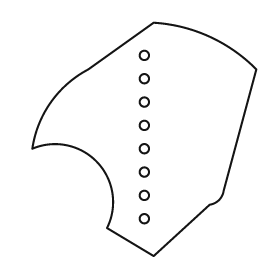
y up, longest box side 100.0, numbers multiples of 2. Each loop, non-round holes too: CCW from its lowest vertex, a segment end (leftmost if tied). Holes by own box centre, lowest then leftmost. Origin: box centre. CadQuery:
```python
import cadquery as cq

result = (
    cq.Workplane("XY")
    .moveTo(4.0, -50.0)
    .lineTo(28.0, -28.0)
    .threePointArc((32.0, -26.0), (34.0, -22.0))
    .lineTo(48.0, 30.0)
    .threePointArc((28.0, 44.0), (4.0, 50.0))
    .lineTo(-24.0, 30.0)
    .threePointArc((-40.0, 16.0), (-48.0, -4.0))
    .threePointArc((-20.0, -10.0), (-16.0, -38.0))
    .close()
    .moveTo(0.0, -34.0)
    .circle(2.0)
    .moveTo(0.0, -24.0)
    .circle(2.0)
    .moveTo(0.0, -14.0)
    .circle(2.0)
    .moveTo(0.0, -4.0)
    .circle(2.0)
    .moveTo(0.0, 6.0)
    .circle(2.0)
    .moveTo(0.0, 16.0)
    .circle(2.0)
    .moveTo(0.0, 26.0)
    .circle(2.0)
    .moveTo(0.0, 36.0)
    .circle(2.0)
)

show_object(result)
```